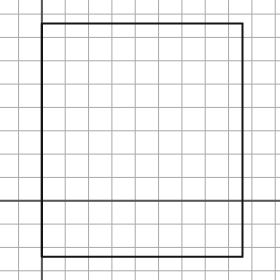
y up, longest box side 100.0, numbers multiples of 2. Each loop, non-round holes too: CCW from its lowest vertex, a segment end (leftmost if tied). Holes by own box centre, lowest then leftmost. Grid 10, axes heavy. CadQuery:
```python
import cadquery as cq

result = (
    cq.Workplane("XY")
    .moveTo(0.0, -24.0)
    .lineTo(86.0, -24.0)
    .lineTo(86.0, 76.0)
    .lineTo(0.0, 76.0)
    .close()
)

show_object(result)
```